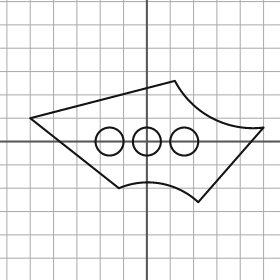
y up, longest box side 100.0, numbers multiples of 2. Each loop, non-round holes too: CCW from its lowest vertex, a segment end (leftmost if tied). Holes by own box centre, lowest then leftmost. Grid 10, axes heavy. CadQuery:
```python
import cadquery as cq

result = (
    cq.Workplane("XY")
    .moveTo(22.0, -26.0)
    .lineTo(50.0, 6.0)
    .threePointArc((28.0, 10.0), (12.0, 26.0))
    .lineTo(-50.0, 10.0)
    .lineTo(-12.0, -20.0)
    .threePointArc((6.0, -18.0), (22.0, -26.0))
    .close()
    .moveTo(-16.0, 0.0)
    .circle(6.0)
    .moveTo(0.0, 0.0)
    .circle(6.0)
    .moveTo(16.0, 0.0)
    .circle(6.0)
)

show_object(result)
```